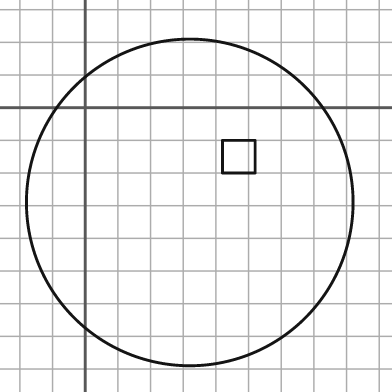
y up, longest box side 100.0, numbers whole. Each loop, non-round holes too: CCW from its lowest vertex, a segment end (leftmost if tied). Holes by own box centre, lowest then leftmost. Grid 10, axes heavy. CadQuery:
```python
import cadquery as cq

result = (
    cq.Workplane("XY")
    .moveTo(32.0, -29.0)
    .circle(50.0)
    .moveTo(42.0, -20.0)
    .lineTo(52.0, -20.0)
    .lineTo(52.0, -10.0)
    .lineTo(42.0, -10.0)
    .close()
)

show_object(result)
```